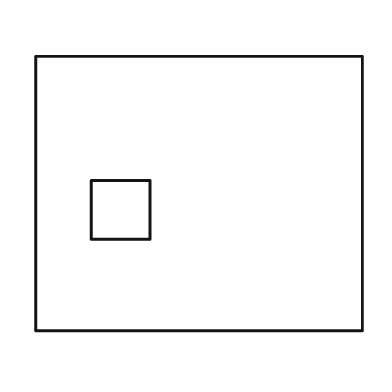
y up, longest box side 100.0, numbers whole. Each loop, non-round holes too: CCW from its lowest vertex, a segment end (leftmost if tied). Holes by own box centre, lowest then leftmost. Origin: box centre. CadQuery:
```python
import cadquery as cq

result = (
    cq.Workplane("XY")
    .moveTo(-50.0, -42.0)
    .lineTo(50.0, -42.0)
    .lineTo(50.0, 42.0)
    .lineTo(-50.0, 42.0)
    .close()
    .moveTo(-33.0, -14.0)
    .lineTo(-15.0, -14.0)
    .lineTo(-15.0, 4.0)
    .lineTo(-33.0, 4.0)
    .close()
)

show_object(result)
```